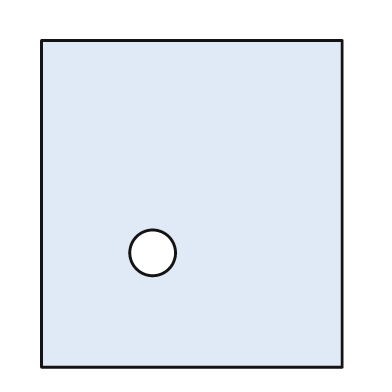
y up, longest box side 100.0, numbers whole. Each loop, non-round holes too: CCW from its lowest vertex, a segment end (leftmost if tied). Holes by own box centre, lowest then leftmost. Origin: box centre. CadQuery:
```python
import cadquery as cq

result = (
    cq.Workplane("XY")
    .moveTo(-46.0, -50.0)
    .lineTo(46.0, -50.0)
    .lineTo(46.0, 50.0)
    .lineTo(-46.0, 50.0)
    .close()
    .moveTo(-12.0, -15.0)
    .circle(7.0)
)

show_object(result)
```